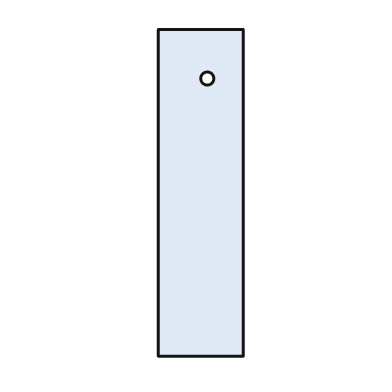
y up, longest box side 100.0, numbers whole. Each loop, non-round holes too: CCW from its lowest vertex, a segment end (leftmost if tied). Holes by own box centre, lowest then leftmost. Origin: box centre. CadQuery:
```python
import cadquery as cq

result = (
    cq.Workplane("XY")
    .moveTo(-13.0, -50.0)
    .lineTo(13.0, -50.0)
    .lineTo(13.0, 50.0)
    .lineTo(-13.0, 50.0)
    .close()
    .moveTo(2.0, 35.0)
    .circle(2.0)
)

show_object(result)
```